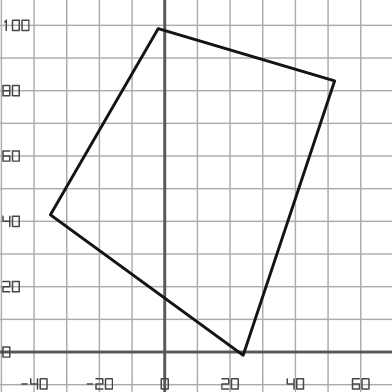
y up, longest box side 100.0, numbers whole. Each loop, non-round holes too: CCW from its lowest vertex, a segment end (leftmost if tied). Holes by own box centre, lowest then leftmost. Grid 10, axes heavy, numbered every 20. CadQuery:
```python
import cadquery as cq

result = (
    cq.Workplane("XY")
    .moveTo(24.0, -1.0)
    .lineTo(52.0, 83.0)
    .lineTo(-2.0, 99.0)
    .lineTo(-35.0, 42.0)
    .close()
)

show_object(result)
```